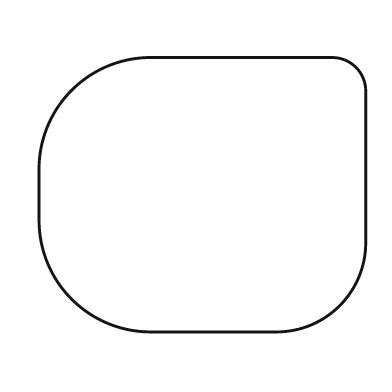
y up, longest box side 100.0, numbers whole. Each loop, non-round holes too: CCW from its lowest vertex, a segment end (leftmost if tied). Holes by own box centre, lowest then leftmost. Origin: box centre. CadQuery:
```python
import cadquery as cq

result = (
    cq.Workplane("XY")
    .moveTo(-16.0, -42.0)
    .lineTo(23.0, -42.0)
    .threePointArc((42.0, -34.0), (50.0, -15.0))
    .lineTo(50.0, 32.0)
    .threePointArc((47.0, 39.0), (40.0, 42.0))
    .lineTo(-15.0, 42.0)
    .threePointArc((-40.0, 32.0), (-50.0, 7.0))
    .lineTo(-50.0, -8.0)
    .threePointArc((-40.0, -32.0), (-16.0, -42.0))
    .close()
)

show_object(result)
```